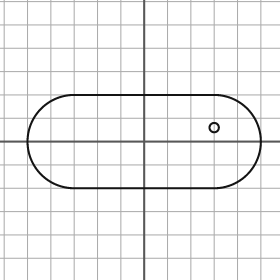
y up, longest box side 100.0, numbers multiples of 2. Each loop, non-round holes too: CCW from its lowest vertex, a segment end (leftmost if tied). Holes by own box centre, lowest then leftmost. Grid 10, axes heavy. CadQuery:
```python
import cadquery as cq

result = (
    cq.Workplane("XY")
    .moveTo(-30.0, -20.0)
    .lineTo(30.0, -20.0)
    .threePointArc((50.0, 0.0), (30.0, 20.0))
    .lineTo(-30.0, 20.0)
    .threePointArc((-50.0, 0.0), (-30.0, -20.0))
    .close()
    .moveTo(30.0, 6.0)
    .circle(2.0)
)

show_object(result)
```